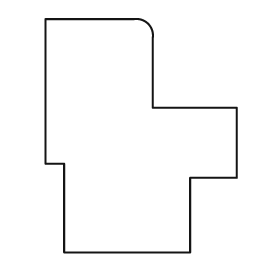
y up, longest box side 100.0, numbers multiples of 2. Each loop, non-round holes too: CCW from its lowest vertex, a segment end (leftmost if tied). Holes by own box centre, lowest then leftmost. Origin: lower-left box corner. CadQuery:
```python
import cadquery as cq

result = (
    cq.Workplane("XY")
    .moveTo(8.0, 0.0)
    .lineTo(62.0, 0.0)
    .lineTo(62.0, 32.0)
    .lineTo(82.0, 32.0)
    .lineTo(82.0, 62.0)
    .lineTo(46.0, 62.0)
    .lineTo(46.0, 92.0)
    .threePointArc((44.0, 98.0), (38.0, 100.0))
    .lineTo(0.0, 100.0)
    .lineTo(0.0, 38.0)
    .lineTo(8.0, 38.0)
    .close()
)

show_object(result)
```